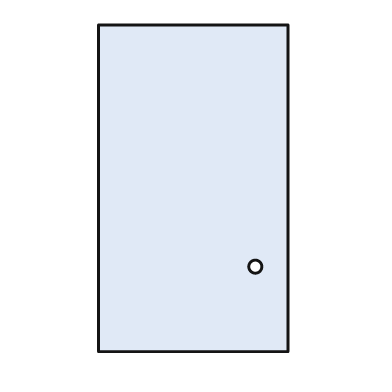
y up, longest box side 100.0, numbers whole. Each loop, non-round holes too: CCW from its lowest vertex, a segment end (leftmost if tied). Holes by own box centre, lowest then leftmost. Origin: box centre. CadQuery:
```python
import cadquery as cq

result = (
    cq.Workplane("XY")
    .moveTo(-29.0, -50.0)
    .lineTo(29.0, -50.0)
    .lineTo(29.0, 50.0)
    .lineTo(-29.0, 50.0)
    .close()
    .moveTo(19.0, -24.0)
    .circle(2.0)
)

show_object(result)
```